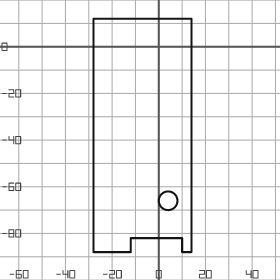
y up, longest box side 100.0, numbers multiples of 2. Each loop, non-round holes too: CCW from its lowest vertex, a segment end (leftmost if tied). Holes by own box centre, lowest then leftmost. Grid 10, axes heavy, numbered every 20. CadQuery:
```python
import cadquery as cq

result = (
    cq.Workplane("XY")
    .moveTo(-28.0, -88.0)
    .lineTo(-12.0, -88.0)
    .lineTo(-12.0, -82.0)
    .lineTo(10.0, -82.0)
    .lineTo(10.0, -88.0)
    .lineTo(14.0, -88.0)
    .lineTo(14.0, 12.0)
    .lineTo(-28.0, 12.0)
    .close()
    .moveTo(4.0, -66.0)
    .circle(4.0)
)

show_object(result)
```